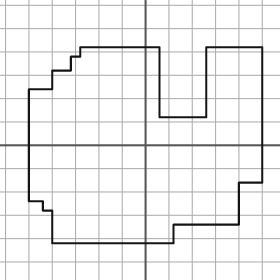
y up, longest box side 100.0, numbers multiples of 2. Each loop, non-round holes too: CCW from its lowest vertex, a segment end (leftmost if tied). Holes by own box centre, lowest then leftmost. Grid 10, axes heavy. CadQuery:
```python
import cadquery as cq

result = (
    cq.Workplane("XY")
    .moveTo(-40.0, -42.0)
    .lineTo(12.0, -42.0)
    .lineTo(12.0, -34.0)
    .lineTo(40.0, -34.0)
    .lineTo(40.0, -16.0)
    .lineTo(50.0, -16.0)
    .lineTo(50.0, 42.0)
    .lineTo(26.0, 42.0)
    .lineTo(26.0, 12.0)
    .lineTo(6.0, 12.0)
    .lineTo(6.0, 42.0)
    .lineTo(-28.0, 42.0)
    .lineTo(-28.0, 38.0)
    .lineTo(-32.0, 38.0)
    .lineTo(-32.0, 32.0)
    .lineTo(-40.0, 32.0)
    .lineTo(-40.0, 24.0)
    .lineTo(-50.0, 24.0)
    .lineTo(-50.0, -24.0)
    .lineTo(-44.0, -24.0)
    .lineTo(-44.0, -28.0)
    .lineTo(-40.0, -28.0)
    .close()
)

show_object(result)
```